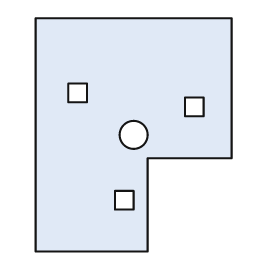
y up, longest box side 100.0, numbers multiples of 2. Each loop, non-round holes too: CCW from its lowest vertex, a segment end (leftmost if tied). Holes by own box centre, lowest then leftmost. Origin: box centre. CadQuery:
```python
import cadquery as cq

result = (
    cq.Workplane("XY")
    .moveTo(-42.0, -50.0)
    .lineTo(6.0, -50.0)
    .lineTo(6.0, -10.0)
    .lineTo(42.0, -10.0)
    .lineTo(42.0, 50.0)
    .lineTo(-42.0, 50.0)
    .close()
    .moveTo(-8.0, -32.0)
    .lineTo(0.0, -32.0)
    .lineTo(0.0, -24.0)
    .lineTo(-8.0, -24.0)
    .close()
    .moveTo(0.0, 0.0)
    .circle(6.0)
    .moveTo(22.0, 8.0)
    .lineTo(30.0, 8.0)
    .lineTo(30.0, 16.0)
    .lineTo(22.0, 16.0)
    .close()
    .moveTo(-28.0, 14.0)
    .lineTo(-20.0, 14.0)
    .lineTo(-20.0, 22.0)
    .lineTo(-28.0, 22.0)
    .close()
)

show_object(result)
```